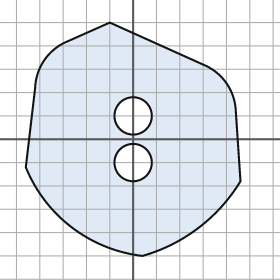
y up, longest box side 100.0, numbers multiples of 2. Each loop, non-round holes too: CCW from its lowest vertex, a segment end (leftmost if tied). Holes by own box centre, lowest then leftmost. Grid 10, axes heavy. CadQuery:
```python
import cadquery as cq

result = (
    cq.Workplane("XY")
    .moveTo(4.0, -50.0)
    .threePointArc((28.0, -38.0), (46.0, -18.0))
    .lineTo(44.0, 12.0)
    .threePointArc((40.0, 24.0), (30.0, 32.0))
    .lineTo(-10.0, 50.0)
    .lineTo(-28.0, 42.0)
    .threePointArc((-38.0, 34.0), (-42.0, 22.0))
    .lineTo(-46.0, -12.0)
    .threePointArc((-26.0, -38.0), (4.0, -50.0))
    .close()
    .moveTo(0.0, -10.0)
    .circle(8.0)
    .moveTo(0.0, 10.0)
    .circle(8.0)
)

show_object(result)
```